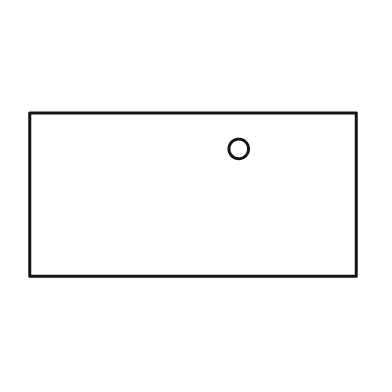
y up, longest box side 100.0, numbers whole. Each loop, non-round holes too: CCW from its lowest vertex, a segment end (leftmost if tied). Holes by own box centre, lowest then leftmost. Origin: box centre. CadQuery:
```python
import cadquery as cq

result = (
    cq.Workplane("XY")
    .moveTo(-50.0, -25.0)
    .lineTo(50.0, -25.0)
    .lineTo(50.0, 25.0)
    .lineTo(-50.0, 25.0)
    .close()
    .moveTo(14.0, 14.0)
    .circle(3.0)
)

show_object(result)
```